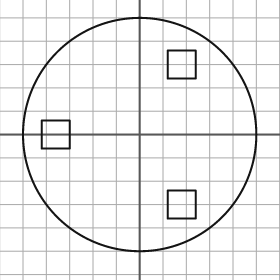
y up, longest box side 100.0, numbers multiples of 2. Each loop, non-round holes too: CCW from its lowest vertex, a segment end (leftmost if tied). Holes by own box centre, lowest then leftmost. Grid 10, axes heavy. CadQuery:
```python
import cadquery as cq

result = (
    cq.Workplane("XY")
    .moveTo(0.0, 0.0)
    .circle(50.0)
    .moveTo(12.0, -36.0)
    .lineTo(24.0, -36.0)
    .lineTo(24.0, -24.0)
    .lineTo(12.0, -24.0)
    .close()
    .moveTo(-42.0, -6.0)
    .lineTo(-30.0, -6.0)
    .lineTo(-30.0, 6.0)
    .lineTo(-42.0, 6.0)
    .close()
    .moveTo(12.0, 24.0)
    .lineTo(24.0, 24.0)
    .lineTo(24.0, 36.0)
    .lineTo(12.0, 36.0)
    .close()
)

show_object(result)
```